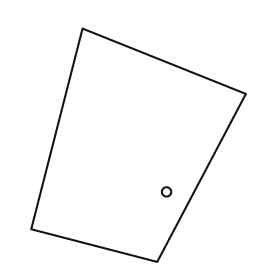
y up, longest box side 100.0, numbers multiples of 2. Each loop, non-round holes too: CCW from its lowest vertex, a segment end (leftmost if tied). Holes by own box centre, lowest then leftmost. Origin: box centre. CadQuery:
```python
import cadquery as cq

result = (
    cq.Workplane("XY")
    .moveTo(8.0, -50.0)
    .lineTo(46.0, 22.0)
    .lineTo(-24.0, 50.0)
    .lineTo(-46.0, -36.0)
    .close()
    .moveTo(12.0, -20.0)
    .circle(2.0)
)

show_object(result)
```